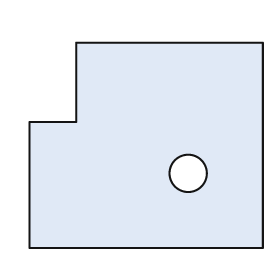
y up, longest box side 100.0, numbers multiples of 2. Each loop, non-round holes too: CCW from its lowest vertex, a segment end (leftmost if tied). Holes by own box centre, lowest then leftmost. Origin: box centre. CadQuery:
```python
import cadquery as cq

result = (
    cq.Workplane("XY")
    .moveTo(-50.0, -44.0)
    .lineTo(50.0, -44.0)
    .lineTo(50.0, 44.0)
    .lineTo(-30.0, 44.0)
    .lineTo(-30.0, 10.0)
    .lineTo(-50.0, 10.0)
    .close()
    .moveTo(18.0, -12.0)
    .circle(8.0)
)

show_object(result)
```